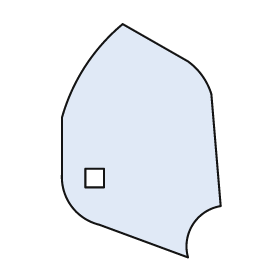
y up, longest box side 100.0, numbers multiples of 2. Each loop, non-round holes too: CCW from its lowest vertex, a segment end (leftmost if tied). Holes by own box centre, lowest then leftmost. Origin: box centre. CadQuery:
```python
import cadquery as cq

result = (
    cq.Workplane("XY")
    .moveTo(20.0, -50.0)
    .threePointArc((22.0, -36.0), (34.0, -28.0))
    .lineTo(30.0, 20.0)
    .threePointArc((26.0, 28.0), (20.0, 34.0))
    .lineTo(-8.0, 50.0)
    .threePointArc((-24.0, 32.0), (-34.0, 10.0))
    .lineTo(-34.0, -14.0)
    .threePointArc((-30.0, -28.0), (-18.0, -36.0))
    .close()
    .moveTo(-24.0, -20.0)
    .lineTo(-16.0, -20.0)
    .lineTo(-16.0, -12.0)
    .lineTo(-24.0, -12.0)
    .close()
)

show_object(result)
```